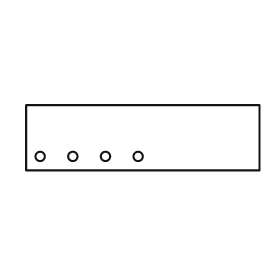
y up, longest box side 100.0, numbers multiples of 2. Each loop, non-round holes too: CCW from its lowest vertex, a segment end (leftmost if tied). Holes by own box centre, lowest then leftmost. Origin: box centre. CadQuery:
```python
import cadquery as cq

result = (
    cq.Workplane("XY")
    .moveTo(-50.0, -14.0)
    .lineTo(50.0, -14.0)
    .lineTo(50.0, 14.0)
    .lineTo(-50.0, 14.0)
    .close()
    .moveTo(-44.0, -8.0)
    .circle(2.0)
    .moveTo(-30.0, -8.0)
    .circle(2.0)
    .moveTo(-16.0, -8.0)
    .circle(2.0)
    .moveTo(-2.0, -8.0)
    .circle(2.0)
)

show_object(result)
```